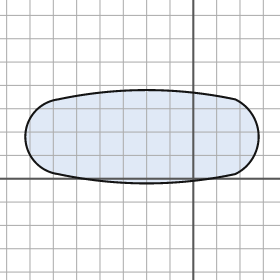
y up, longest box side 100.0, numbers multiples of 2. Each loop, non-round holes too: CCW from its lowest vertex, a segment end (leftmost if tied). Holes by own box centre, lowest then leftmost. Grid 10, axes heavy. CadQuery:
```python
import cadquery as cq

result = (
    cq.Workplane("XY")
    .moveTo(-58.0, 2.0)
    .threePointArc((-20.0, -2.0), (18.0, 2.0))
    .threePointArc((28.0, 18.0), (18.0, 34.0))
    .threePointArc((-20.0, 38.0), (-58.0, 34.0))
    .threePointArc((-72.0, 18.0), (-58.0, 2.0))
    .close()
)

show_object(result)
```